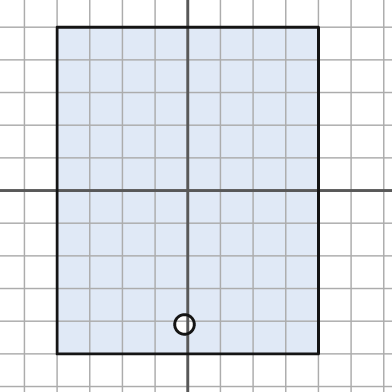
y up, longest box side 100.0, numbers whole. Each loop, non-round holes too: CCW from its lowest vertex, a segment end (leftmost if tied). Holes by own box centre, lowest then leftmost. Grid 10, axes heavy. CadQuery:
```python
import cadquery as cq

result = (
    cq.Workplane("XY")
    .moveTo(-40.0, -50.0)
    .lineTo(40.0, -50.0)
    .lineTo(40.0, 50.0)
    .lineTo(-40.0, 50.0)
    .close()
    .moveTo(-1.0, -41.0)
    .circle(3.0)
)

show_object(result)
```